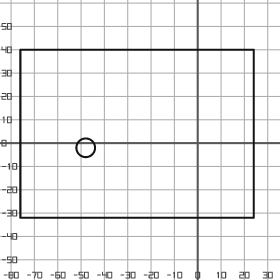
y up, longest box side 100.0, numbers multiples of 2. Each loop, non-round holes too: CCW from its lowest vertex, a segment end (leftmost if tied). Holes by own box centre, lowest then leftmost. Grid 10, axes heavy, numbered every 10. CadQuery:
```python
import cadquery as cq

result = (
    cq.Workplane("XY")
    .moveTo(-76.0, -32.0)
    .lineTo(24.0, -32.0)
    .lineTo(24.0, 40.0)
    .lineTo(-76.0, 40.0)
    .close()
    .moveTo(-48.0, -2.0)
    .circle(4.0)
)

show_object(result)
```